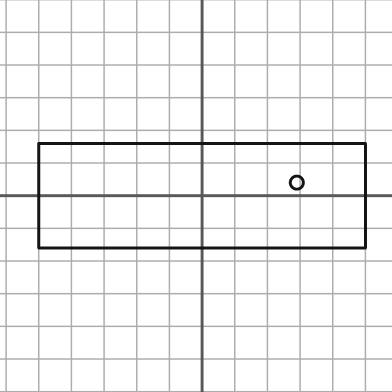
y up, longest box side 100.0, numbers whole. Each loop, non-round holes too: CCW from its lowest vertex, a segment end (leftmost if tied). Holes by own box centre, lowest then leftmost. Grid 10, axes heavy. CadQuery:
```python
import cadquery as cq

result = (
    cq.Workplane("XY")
    .moveTo(-50.0, -16.0)
    .lineTo(50.0, -16.0)
    .lineTo(50.0, 16.0)
    .lineTo(-50.0, 16.0)
    .close()
    .moveTo(29.0, 4.0)
    .circle(2.0)
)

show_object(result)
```